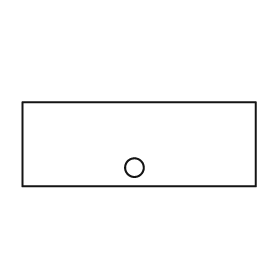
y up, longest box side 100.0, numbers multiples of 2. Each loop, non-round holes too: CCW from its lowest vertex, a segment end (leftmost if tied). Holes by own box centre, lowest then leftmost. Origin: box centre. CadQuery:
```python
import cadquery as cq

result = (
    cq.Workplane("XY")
    .moveTo(-50.0, -18.0)
    .lineTo(50.0, -18.0)
    .lineTo(50.0, 18.0)
    .lineTo(-50.0, 18.0)
    .close()
    .moveTo(-2.0, -10.0)
    .circle(4.0)
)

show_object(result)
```